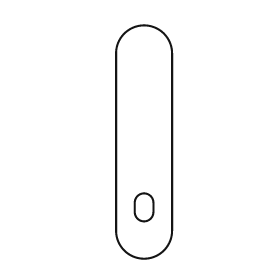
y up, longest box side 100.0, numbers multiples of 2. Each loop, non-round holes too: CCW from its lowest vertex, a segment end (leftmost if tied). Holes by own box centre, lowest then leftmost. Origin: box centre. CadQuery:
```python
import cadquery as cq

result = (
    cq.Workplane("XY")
    .moveTo(-12.0, -38.0)
    .threePointArc((0.0, -50.0), (12.0, -38.0))
    .lineTo(12.0, 38.0)
    .threePointArc((0.0, 50.0), (-12.0, 38.0))
    .close()
    .moveTo(-4.0, -30.0)
    .threePointArc((0.0, -34.0), (4.0, -30.0))
    .lineTo(4.0, -26.0)
    .threePointArc((0.0, -22.0), (-4.0, -26.0))
    .close()
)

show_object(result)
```